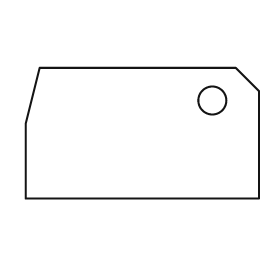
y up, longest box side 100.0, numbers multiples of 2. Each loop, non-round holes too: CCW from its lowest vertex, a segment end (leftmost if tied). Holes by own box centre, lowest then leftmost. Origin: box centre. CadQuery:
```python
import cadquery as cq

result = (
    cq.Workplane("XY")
    .moveTo(-50.0, -28.0)
    .lineTo(50.0, -28.0)
    .lineTo(50.0, 18.0)
    .lineTo(40.0, 28.0)
    .lineTo(-44.0, 28.0)
    .lineTo(-50.0, 4.0)
    .close()
    .moveTo(30.0, 14.0)
    .circle(6.0)
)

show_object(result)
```